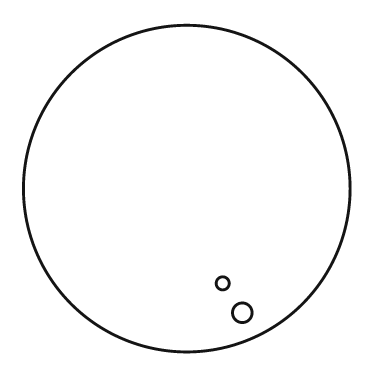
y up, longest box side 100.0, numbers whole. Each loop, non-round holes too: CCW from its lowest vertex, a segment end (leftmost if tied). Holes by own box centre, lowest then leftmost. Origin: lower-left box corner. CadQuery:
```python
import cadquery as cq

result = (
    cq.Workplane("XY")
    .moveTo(50.0, 50.0)
    .circle(50.0)
    .moveTo(67.0, 12.0)
    .circle(3.0)
    .moveTo(61.0, 21.0)
    .circle(2.0)
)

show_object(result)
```